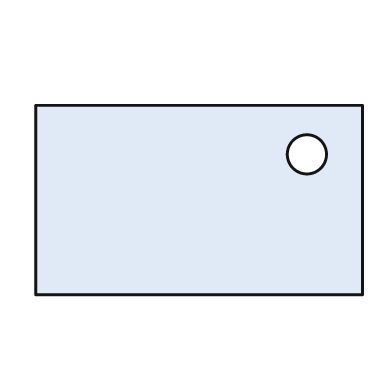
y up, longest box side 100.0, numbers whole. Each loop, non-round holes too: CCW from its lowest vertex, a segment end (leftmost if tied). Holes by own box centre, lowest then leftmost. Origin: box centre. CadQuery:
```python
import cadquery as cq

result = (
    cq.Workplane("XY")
    .moveTo(-50.0, -29.0)
    .lineTo(50.0, -29.0)
    .lineTo(50.0, 29.0)
    .lineTo(-50.0, 29.0)
    .close()
    .moveTo(33.0, 14.0)
    .circle(6.0)
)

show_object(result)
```